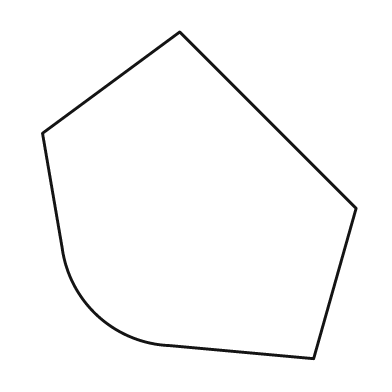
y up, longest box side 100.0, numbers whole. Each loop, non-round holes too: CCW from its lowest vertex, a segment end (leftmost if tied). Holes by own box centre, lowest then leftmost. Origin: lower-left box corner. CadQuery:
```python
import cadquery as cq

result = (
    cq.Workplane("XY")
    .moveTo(83.0, 0.0)
    .lineTo(96.0, 46.0)
    .lineTo(42.0, 100.0)
    .lineTo(0.0, 69.0)
    .lineTo(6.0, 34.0)
    .threePointArc((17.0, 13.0), (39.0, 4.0))
    .close()
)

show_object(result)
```